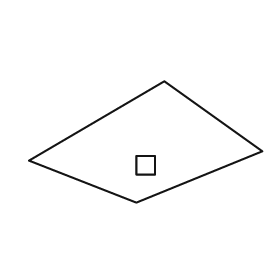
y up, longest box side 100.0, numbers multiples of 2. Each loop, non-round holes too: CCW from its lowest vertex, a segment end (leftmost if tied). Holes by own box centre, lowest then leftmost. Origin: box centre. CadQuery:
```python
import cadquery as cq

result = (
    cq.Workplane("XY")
    .moveTo(-4.0, -26.0)
    .lineTo(50.0, -4.0)
    .lineTo(8.0, 26.0)
    .lineTo(-50.0, -8.0)
    .close()
    .moveTo(-4.0, -14.0)
    .lineTo(4.0, -14.0)
    .lineTo(4.0, -6.0)
    .lineTo(-4.0, -6.0)
    .close()
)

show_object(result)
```